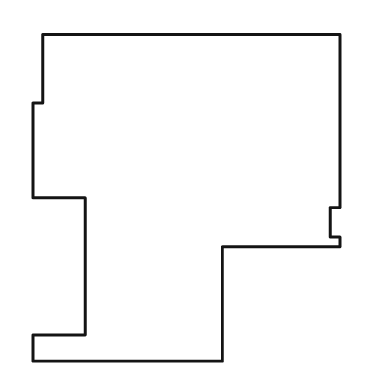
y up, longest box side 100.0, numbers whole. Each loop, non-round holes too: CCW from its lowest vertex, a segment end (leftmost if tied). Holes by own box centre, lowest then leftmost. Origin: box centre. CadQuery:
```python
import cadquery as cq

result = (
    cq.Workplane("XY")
    .moveTo(-47.0, -50.0)
    .lineTo(11.0, -50.0)
    .lineTo(11.0, -15.0)
    .lineTo(47.0, -15.0)
    .lineTo(47.0, -12.0)
    .lineTo(44.0, -12.0)
    .lineTo(44.0, -3.0)
    .lineTo(47.0, -3.0)
    .lineTo(47.0, 50.0)
    .lineTo(-44.0, 50.0)
    .lineTo(-44.0, 29.0)
    .lineTo(-47.0, 29.0)
    .lineTo(-47.0, 0.0)
    .lineTo(-31.0, 0.0)
    .lineTo(-31.0, -42.0)
    .lineTo(-47.0, -42.0)
    .close()
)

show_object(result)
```